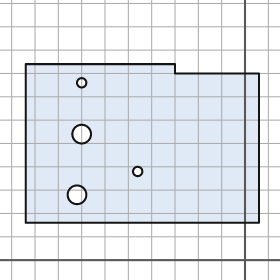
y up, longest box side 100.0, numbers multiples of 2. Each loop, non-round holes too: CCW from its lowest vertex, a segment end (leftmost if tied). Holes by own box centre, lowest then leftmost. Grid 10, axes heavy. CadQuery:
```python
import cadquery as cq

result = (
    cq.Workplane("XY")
    .moveTo(-94.0, 16.0)
    .lineTo(6.0, 16.0)
    .lineTo(6.0, 80.0)
    .lineTo(-30.0, 80.0)
    .lineTo(-30.0, 84.0)
    .lineTo(-94.0, 84.0)
    .close()
    .moveTo(-72.0, 28.0)
    .circle(4.0)
    .moveTo(-46.0, 38.0)
    .circle(2.0)
    .moveTo(-70.0, 54.0)
    .circle(4.0)
    .moveTo(-70.0, 76.0)
    .circle(2.0)
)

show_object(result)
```